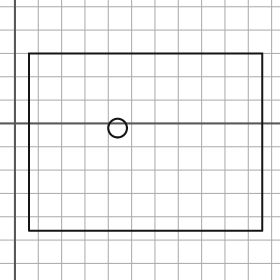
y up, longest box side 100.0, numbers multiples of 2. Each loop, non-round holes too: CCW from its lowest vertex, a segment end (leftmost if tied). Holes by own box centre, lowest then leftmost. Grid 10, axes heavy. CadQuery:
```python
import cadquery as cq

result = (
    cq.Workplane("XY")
    .moveTo(6.0, -46.0)
    .lineTo(106.0, -46.0)
    .lineTo(106.0, 30.0)
    .lineTo(6.0, 30.0)
    .close()
    .moveTo(44.0, -2.0)
    .circle(4.0)
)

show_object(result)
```